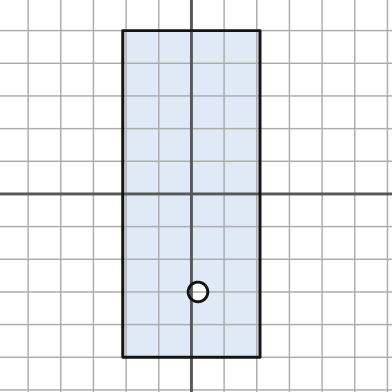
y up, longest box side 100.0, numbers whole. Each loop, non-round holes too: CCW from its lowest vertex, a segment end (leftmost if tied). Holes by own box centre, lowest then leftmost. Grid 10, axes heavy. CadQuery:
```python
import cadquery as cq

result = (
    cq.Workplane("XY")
    .moveTo(-21.0, -50.0)
    .lineTo(21.0, -50.0)
    .lineTo(21.0, 50.0)
    .lineTo(-21.0, 50.0)
    .close()
    .moveTo(2.0, -30.0)
    .circle(3.0)
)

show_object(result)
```